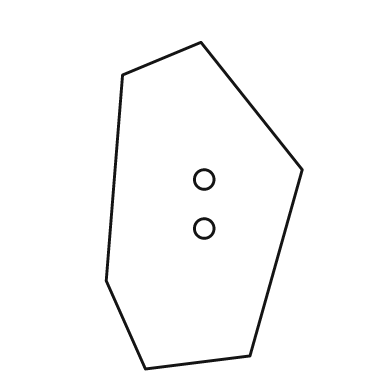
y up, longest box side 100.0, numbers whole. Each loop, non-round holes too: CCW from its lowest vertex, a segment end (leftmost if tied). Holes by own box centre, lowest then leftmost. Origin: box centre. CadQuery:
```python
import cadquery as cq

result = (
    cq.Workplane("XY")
    .moveTo(-18.0, -50.0)
    .lineTo(14.0, -46.0)
    .lineTo(30.0, 11.0)
    .lineTo(-1.0, 50.0)
    .lineTo(-25.0, 40.0)
    .lineTo(-30.0, -23.0)
    .close()
    .moveTo(0.0, -7.0)
    .circle(3.0)
    .moveTo(0.0, 8.0)
    .circle(3.0)
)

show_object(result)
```